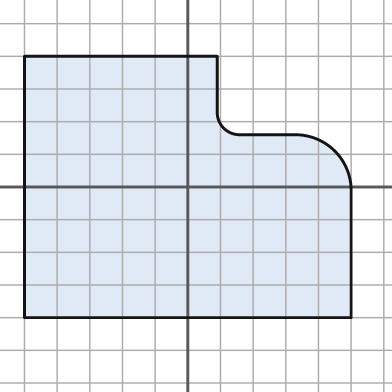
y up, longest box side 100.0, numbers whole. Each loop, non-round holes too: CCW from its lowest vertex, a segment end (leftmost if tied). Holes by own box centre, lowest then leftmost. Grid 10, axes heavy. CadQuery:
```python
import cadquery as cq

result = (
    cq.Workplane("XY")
    .moveTo(-50.0, -40.0)
    .lineTo(50.0, -40.0)
    .lineTo(50.0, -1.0)
    .threePointArc((45.0, 11.0), (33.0, 16.0))
    .lineTo(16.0, 16.0)
    .threePointArc((11.0, 18.0), (9.0, 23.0))
    .lineTo(9.0, 40.0)
    .lineTo(-50.0, 40.0)
    .close()
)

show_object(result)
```